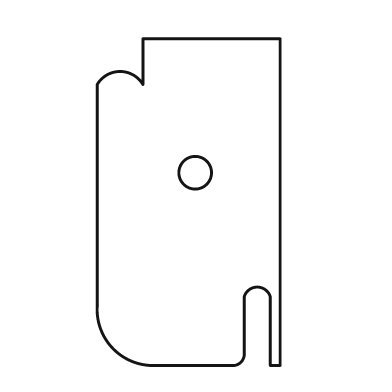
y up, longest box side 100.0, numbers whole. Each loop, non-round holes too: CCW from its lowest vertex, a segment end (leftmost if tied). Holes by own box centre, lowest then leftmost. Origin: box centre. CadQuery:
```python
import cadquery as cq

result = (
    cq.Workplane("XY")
    .moveTo(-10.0, -50.0)
    .lineTo(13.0, -50.0)
    .threePointArc((16.0, -49.0), (17.0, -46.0))
    .lineTo(17.0, -29.0)
    .threePointArc((21.0, -26.0), (25.0, -29.0))
    .lineTo(25.0, -50.0)
    .lineTo(28.0, -50.0)
    .lineTo(28.0, 50.0)
    .lineTo(-14.0, 50.0)
    .lineTo(-14.0, 36.0)
    .threePointArc((-21.0, 40.0), (-28.0, 36.0))
    .lineTo(-28.0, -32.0)
    .threePointArc((-23.0, -45.0), (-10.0, -50.0))
    .close()
    .moveTo(2.0, 9.0)
    .circle(5.0)
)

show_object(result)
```